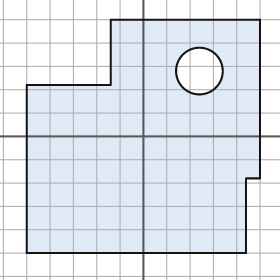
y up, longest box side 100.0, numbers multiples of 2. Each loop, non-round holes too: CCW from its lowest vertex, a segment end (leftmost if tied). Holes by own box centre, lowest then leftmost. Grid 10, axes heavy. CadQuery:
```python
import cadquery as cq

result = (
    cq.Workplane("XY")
    .moveTo(-50.0, -50.0)
    .lineTo(44.0, -50.0)
    .lineTo(44.0, -18.0)
    .lineTo(50.0, -18.0)
    .lineTo(50.0, 50.0)
    .lineTo(-14.0, 50.0)
    .lineTo(-14.0, 22.0)
    .lineTo(-50.0, 22.0)
    .close()
    .moveTo(24.0, 28.0)
    .circle(10.0)
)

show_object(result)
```